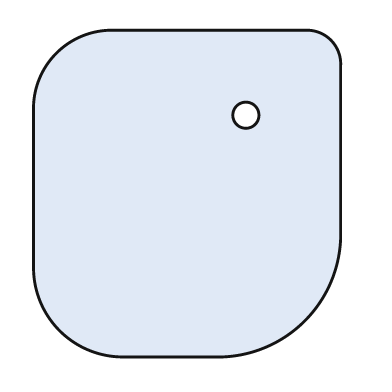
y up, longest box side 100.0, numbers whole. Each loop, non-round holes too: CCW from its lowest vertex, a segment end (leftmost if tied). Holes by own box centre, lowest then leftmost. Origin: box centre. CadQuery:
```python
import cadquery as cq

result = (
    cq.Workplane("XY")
    .moveTo(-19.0, -50.0)
    .lineTo(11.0, -50.0)
    .threePointArc((36.0, -39.0), (47.0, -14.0))
    .lineTo(47.0, 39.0)
    .threePointArc((44.0, 47.0), (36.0, 50.0))
    .lineTo(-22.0, 50.0)
    .threePointArc((-40.0, 43.0), (-47.0, 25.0))
    .lineTo(-47.0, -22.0)
    .threePointArc((-39.0, -42.0), (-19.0, -50.0))
    .close()
    .moveTo(18.0, 24.0)
    .circle(4.0)
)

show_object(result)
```